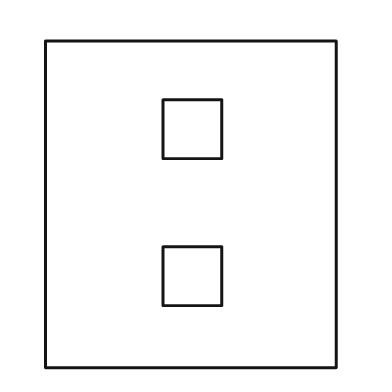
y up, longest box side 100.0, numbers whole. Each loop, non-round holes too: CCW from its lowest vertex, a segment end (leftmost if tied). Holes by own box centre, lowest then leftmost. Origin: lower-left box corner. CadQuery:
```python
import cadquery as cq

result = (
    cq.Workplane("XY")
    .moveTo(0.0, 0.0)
    .lineTo(89.0, 0.0)
    .lineTo(89.0, 100.0)
    .lineTo(0.0, 100.0)
    .close()
    .moveTo(36.0, 19.0)
    .lineTo(54.0, 19.0)
    .lineTo(54.0, 37.0)
    .lineTo(36.0, 37.0)
    .close()
    .moveTo(36.0, 64.0)
    .lineTo(54.0, 64.0)
    .lineTo(54.0, 82.0)
    .lineTo(36.0, 82.0)
    .close()
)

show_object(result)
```